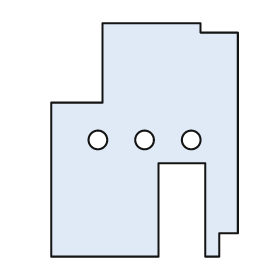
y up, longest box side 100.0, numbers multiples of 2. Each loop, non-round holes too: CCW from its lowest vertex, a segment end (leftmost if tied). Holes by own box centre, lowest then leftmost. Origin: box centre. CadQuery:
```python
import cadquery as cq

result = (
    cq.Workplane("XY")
    .moveTo(-40.0, -50.0)
    .lineTo(6.0, -50.0)
    .lineTo(6.0, -10.0)
    .lineTo(26.0, -10.0)
    .lineTo(26.0, -50.0)
    .lineTo(32.0, -50.0)
    .lineTo(32.0, -40.0)
    .lineTo(40.0, -40.0)
    .lineTo(40.0, 46.0)
    .lineTo(24.0, 46.0)
    .lineTo(24.0, 50.0)
    .lineTo(-18.0, 50.0)
    .lineTo(-18.0, 16.0)
    .lineTo(-40.0, 16.0)
    .close()
    .moveTo(-20.0, 0.0)
    .circle(4.0)
    .moveTo(0.0, 0.0)
    .circle(4.0)
    .moveTo(20.0, 0.0)
    .circle(4.0)
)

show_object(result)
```